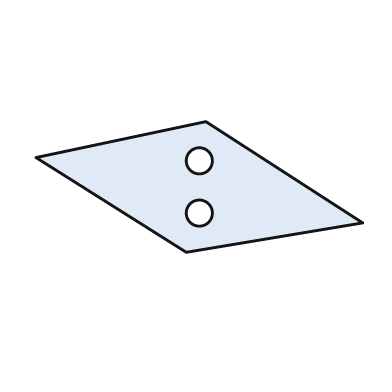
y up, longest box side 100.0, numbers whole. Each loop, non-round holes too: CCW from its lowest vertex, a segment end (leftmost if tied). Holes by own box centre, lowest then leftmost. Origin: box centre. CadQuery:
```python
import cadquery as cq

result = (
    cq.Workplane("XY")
    .moveTo(-4.0, -20.0)
    .lineTo(50.0, -11.0)
    .lineTo(2.0, 20.0)
    .lineTo(-50.0, 9.0)
    .close()
    .moveTo(0.0, -8.0)
    .circle(4.0)
    .moveTo(0.0, 8.0)
    .circle(4.0)
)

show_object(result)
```